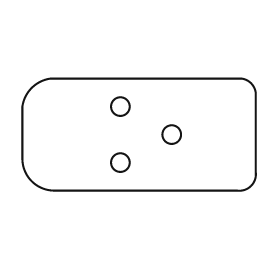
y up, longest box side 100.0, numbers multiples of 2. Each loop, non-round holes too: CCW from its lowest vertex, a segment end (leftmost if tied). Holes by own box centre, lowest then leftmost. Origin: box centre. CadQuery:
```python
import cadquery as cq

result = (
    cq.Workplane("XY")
    .moveTo(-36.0, -24.0)
    .lineTo(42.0, -24.0)
    .threePointArc((48.0, -22.0), (50.0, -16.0))
    .lineTo(50.0, 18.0)
    .threePointArc((48.0, 22.0), (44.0, 24.0))
    .lineTo(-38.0, 24.0)
    .threePointArc((-46.0, 20.0), (-50.0, 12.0))
    .lineTo(-50.0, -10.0)
    .threePointArc((-46.0, -20.0), (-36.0, -24.0))
    .close()
    .moveTo(-8.0, -12.0)
    .circle(4.0)
    .moveTo(14.0, 0.0)
    .circle(4.0)
    .moveTo(-8.0, 12.0)
    .circle(4.0)
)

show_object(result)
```